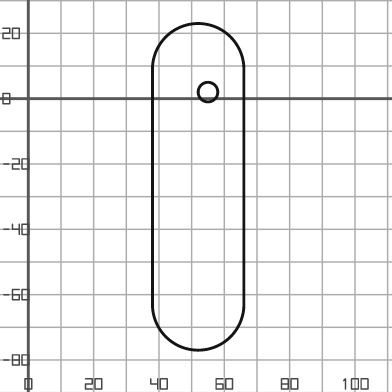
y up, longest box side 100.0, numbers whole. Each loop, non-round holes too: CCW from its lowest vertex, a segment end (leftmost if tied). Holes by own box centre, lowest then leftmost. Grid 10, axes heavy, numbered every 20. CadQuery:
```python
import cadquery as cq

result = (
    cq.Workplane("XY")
    .moveTo(38.0, -63.0)
    .threePointArc((52.0, -77.0), (66.0, -63.0))
    .lineTo(66.0, 9.0)
    .threePointArc((52.0, 23.0), (38.0, 9.0))
    .close()
    .moveTo(55.0, 2.0)
    .circle(3.0)
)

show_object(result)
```